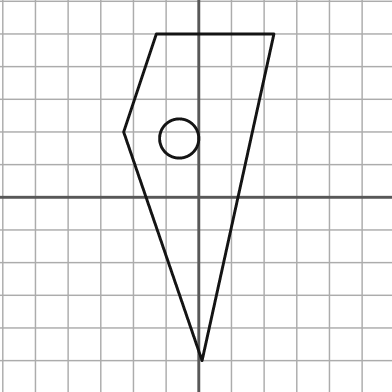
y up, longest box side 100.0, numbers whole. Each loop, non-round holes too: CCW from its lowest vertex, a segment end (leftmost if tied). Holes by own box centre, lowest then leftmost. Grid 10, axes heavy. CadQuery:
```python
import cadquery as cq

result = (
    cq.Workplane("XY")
    .moveTo(1.0, -50.0)
    .lineTo(23.0, 50.0)
    .lineTo(-13.0, 50.0)
    .lineTo(-23.0, 20.0)
    .close()
    .moveTo(-6.0, 18.0)
    .circle(6.0)
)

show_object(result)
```